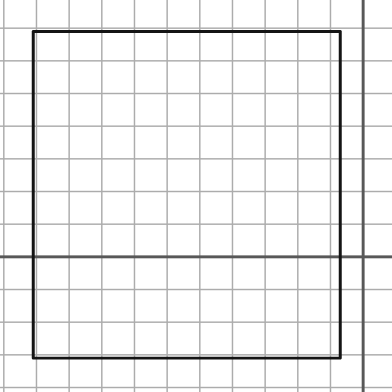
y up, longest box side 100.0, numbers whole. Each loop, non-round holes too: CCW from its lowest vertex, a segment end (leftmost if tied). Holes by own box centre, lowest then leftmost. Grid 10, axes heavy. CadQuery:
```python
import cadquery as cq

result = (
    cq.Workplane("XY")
    .moveTo(-101.0, -31.0)
    .lineTo(-7.0, -31.0)
    .lineTo(-7.0, 69.0)
    .lineTo(-101.0, 69.0)
    .close()
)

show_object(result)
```